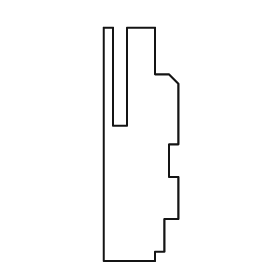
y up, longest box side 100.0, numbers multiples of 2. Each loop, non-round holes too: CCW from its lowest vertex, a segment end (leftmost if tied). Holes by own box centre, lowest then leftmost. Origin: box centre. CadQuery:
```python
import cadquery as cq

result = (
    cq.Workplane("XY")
    .moveTo(-16.0, -50.0)
    .lineTo(6.0, -50.0)
    .lineTo(6.0, -46.0)
    .lineTo(10.0, -46.0)
    .lineTo(10.0, -32.0)
    .lineTo(16.0, -32.0)
    .lineTo(16.0, -14.0)
    .lineTo(12.0, -14.0)
    .lineTo(12.0, 0.0)
    .lineTo(16.0, 0.0)
    .lineTo(16.0, 26.0)
    .lineTo(12.0, 30.0)
    .lineTo(6.0, 30.0)
    .lineTo(6.0, 50.0)
    .lineTo(-6.0, 50.0)
    .lineTo(-6.0, 8.0)
    .lineTo(-12.0, 8.0)
    .lineTo(-12.0, 50.0)
    .lineTo(-16.0, 50.0)
    .close()
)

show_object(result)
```